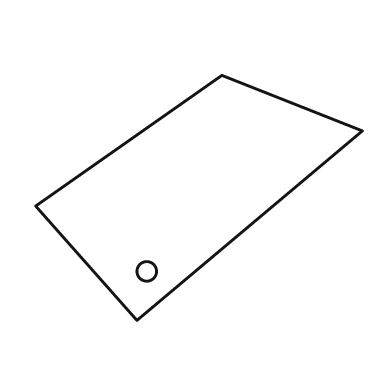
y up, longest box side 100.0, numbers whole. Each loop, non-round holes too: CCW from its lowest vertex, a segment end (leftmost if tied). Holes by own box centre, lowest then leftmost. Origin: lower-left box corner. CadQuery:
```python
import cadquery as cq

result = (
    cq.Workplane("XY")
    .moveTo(31.0, 0.0)
    .lineTo(100.0, 58.0)
    .lineTo(57.0, 75.0)
    .lineTo(0.0, 35.0)
    .close()
    .moveTo(34.0, 15.0)
    .circle(3.0)
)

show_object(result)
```